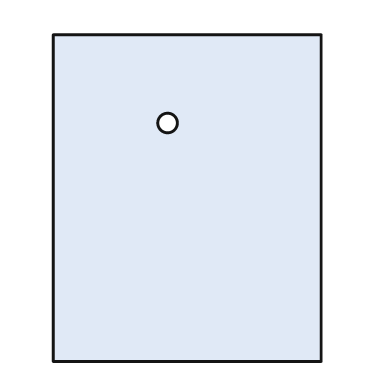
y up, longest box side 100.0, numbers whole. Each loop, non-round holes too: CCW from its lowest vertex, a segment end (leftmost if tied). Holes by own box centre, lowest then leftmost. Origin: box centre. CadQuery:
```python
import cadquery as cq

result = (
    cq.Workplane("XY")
    .moveTo(-41.0, -50.0)
    .lineTo(41.0, -50.0)
    .lineTo(41.0, 50.0)
    .lineTo(-41.0, 50.0)
    .close()
    .moveTo(-6.0, 23.0)
    .circle(3.0)
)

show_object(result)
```